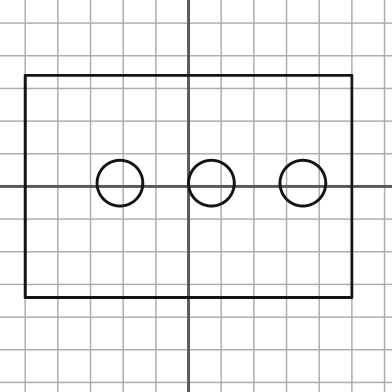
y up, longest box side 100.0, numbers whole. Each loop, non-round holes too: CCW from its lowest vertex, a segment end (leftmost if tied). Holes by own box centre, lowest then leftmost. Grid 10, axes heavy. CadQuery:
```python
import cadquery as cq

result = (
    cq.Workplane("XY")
    .moveTo(-50.0, -34.0)
    .lineTo(50.0, -34.0)
    .lineTo(50.0, 34.0)
    .lineTo(-50.0, 34.0)
    .close()
    .moveTo(-21.0, 1.0)
    .circle(7.0)
    .moveTo(7.0, 1.0)
    .circle(7.0)
    .moveTo(35.0, 1.0)
    .circle(7.0)
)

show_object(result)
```